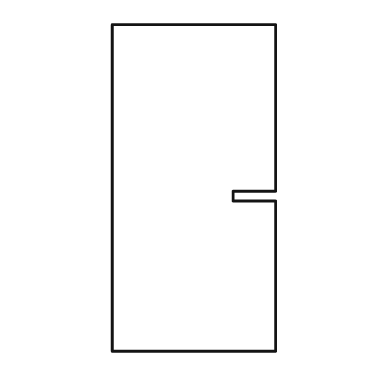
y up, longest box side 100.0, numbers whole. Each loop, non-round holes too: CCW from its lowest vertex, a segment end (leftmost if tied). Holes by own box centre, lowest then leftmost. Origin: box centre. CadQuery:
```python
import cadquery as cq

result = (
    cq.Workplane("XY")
    .moveTo(-25.0, -50.0)
    .lineTo(25.0, -50.0)
    .lineTo(25.0, -4.0)
    .lineTo(12.0, -4.0)
    .lineTo(12.0, -1.0)
    .lineTo(25.0, -1.0)
    .lineTo(25.0, 50.0)
    .lineTo(-25.0, 50.0)
    .close()
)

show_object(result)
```